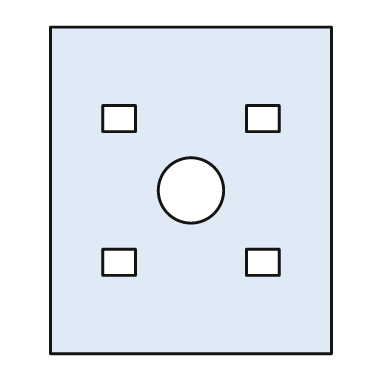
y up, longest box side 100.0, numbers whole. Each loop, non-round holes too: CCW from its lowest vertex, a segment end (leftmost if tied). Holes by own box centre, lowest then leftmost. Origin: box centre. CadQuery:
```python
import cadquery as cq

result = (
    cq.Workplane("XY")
    .moveTo(-43.0, -50.0)
    .lineTo(43.0, -50.0)
    .lineTo(43.0, 50.0)
    .lineTo(-43.0, 50.0)
    .close()
    .moveTo(-27.0, -26.0)
    .lineTo(-17.0, -26.0)
    .lineTo(-17.0, -18.0)
    .lineTo(-27.0, -18.0)
    .close()
    .moveTo(17.0, -26.0)
    .lineTo(27.0, -26.0)
    .lineTo(27.0, -18.0)
    .lineTo(17.0, -18.0)
    .close()
    .moveTo(0.0, 0.0)
    .circle(10.0)
    .moveTo(-27.0, 18.0)
    .lineTo(-17.0, 18.0)
    .lineTo(-17.0, 26.0)
    .lineTo(-27.0, 26.0)
    .close()
    .moveTo(17.0, 18.0)
    .lineTo(27.0, 18.0)
    .lineTo(27.0, 26.0)
    .lineTo(17.0, 26.0)
    .close()
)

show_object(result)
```